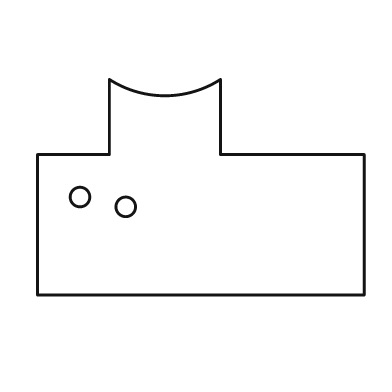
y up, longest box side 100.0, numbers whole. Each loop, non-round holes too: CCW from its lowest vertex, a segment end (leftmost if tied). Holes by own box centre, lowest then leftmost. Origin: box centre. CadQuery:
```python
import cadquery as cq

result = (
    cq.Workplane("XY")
    .moveTo(-50.0, -33.0)
    .lineTo(50.0, -33.0)
    .lineTo(50.0, 10.0)
    .lineTo(6.0, 10.0)
    .lineTo(6.0, 33.0)
    .threePointArc((-11.0, 28.0), (-28.0, 33.0))
    .lineTo(-28.0, 10.0)
    .lineTo(-50.0, 10.0)
    .close()
    .moveTo(-23.0, -6.0)
    .circle(3.0)
    .moveTo(-37.0, -3.0)
    .circle(3.0)
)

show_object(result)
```